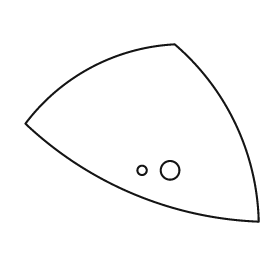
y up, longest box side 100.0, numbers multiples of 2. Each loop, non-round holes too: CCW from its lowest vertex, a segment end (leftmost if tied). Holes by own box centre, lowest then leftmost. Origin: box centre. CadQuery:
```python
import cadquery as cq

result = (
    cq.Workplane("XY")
    .moveTo(50.0, -38.0)
    .threePointArc((40.0, 4.0), (14.0, 38.0))
    .threePointArc((-22.0, 28.0), (-50.0, 4.0))
    .threePointArc((-4.0, -26.0), (50.0, -38.0))
    .close()
    .moveTo(0.0, -16.0)
    .circle(2.0)
    .moveTo(12.0, -16.0)
    .circle(4.0)
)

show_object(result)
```